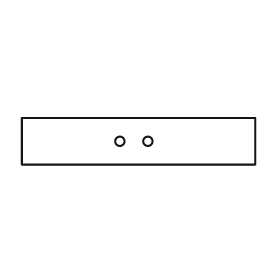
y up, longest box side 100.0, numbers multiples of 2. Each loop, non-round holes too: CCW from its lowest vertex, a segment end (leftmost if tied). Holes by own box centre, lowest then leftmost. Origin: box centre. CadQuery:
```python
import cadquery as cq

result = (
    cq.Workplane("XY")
    .moveTo(-50.0, -10.0)
    .lineTo(50.0, -10.0)
    .lineTo(50.0, 10.0)
    .lineTo(-50.0, 10.0)
    .close()
    .moveTo(-8.0, 0.0)
    .circle(2.0)
    .moveTo(4.0, 0.0)
    .circle(2.0)
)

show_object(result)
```